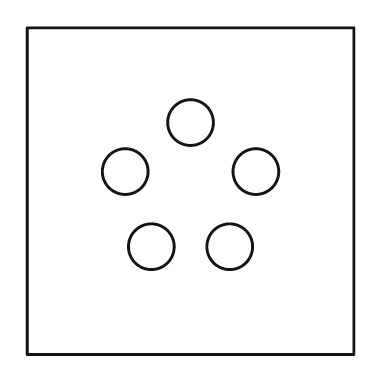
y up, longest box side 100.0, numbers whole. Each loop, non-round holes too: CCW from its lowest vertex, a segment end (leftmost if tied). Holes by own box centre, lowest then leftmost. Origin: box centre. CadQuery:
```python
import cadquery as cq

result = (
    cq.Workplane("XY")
    .moveTo(-50.0, -50.0)
    .lineTo(50.0, -50.0)
    .lineTo(50.0, 50.0)
    .lineTo(-50.0, 50.0)
    .close()
    .moveTo(-12.0, -17.0)
    .circle(7.0)
    .moveTo(12.0, -17.0)
    .circle(7.0)
    .moveTo(-20.0, 6.0)
    .circle(7.0)
    .moveTo(20.0, 6.0)
    .circle(7.0)
    .moveTo(0.0, 21.0)
    .circle(7.0)
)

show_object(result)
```